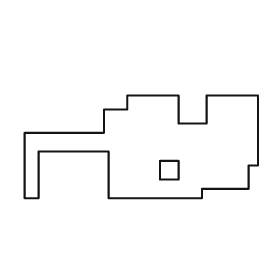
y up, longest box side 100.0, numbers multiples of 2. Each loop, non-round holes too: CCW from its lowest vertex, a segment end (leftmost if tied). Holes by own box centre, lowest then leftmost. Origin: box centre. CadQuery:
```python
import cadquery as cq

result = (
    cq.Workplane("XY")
    .moveTo(-50.0, -22.0)
    .lineTo(-44.0, -22.0)
    .lineTo(-44.0, -2.0)
    .lineTo(-14.0, -2.0)
    .lineTo(-14.0, -22.0)
    .lineTo(26.0, -22.0)
    .lineTo(26.0, -18.0)
    .lineTo(46.0, -18.0)
    .lineTo(46.0, -8.0)
    .lineTo(50.0, -8.0)
    .lineTo(50.0, 22.0)
    .lineTo(28.0, 22.0)
    .lineTo(28.0, 10.0)
    .lineTo(16.0, 10.0)
    .lineTo(16.0, 22.0)
    .lineTo(-6.0, 22.0)
    .lineTo(-6.0, 16.0)
    .lineTo(-16.0, 16.0)
    .lineTo(-16.0, 6.0)
    .lineTo(-50.0, 6.0)
    .close()
    .moveTo(8.0, -14.0)
    .lineTo(16.0, -14.0)
    .lineTo(16.0, -6.0)
    .lineTo(8.0, -6.0)
    .close()
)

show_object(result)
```